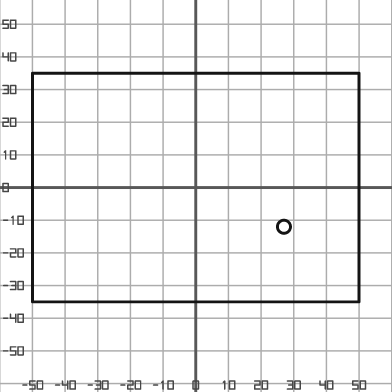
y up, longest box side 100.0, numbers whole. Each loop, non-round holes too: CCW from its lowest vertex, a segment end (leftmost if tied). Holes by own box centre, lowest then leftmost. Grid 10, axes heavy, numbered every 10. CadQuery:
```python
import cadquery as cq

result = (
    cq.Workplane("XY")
    .moveTo(-50.0, -35.0)
    .lineTo(50.0, -35.0)
    .lineTo(50.0, 35.0)
    .lineTo(-50.0, 35.0)
    .close()
    .moveTo(27.0, -12.0)
    .circle(2.0)
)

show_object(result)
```